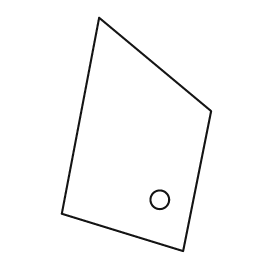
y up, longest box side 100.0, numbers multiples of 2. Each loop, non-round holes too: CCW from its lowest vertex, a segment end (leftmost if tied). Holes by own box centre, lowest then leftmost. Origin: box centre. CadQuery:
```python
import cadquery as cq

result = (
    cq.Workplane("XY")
    .moveTo(20.0, -50.0)
    .lineTo(32.0, 10.0)
    .lineTo(-16.0, 50.0)
    .lineTo(-32.0, -34.0)
    .close()
    .moveTo(10.0, -28.0)
    .circle(4.0)
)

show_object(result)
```